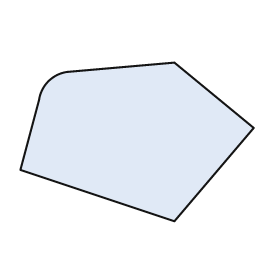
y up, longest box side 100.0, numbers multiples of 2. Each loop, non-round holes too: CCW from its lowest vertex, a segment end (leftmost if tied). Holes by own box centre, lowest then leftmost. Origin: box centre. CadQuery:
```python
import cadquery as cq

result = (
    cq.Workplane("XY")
    .moveTo(16.0, -34.0)
    .lineTo(50.0, 6.0)
    .lineTo(16.0, 34.0)
    .lineTo(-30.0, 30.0)
    .threePointArc((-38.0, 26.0), (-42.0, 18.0))
    .lineTo(-50.0, -12.0)
    .close()
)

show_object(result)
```